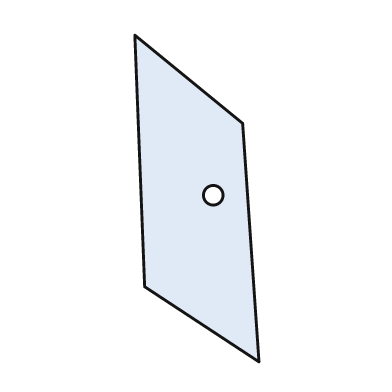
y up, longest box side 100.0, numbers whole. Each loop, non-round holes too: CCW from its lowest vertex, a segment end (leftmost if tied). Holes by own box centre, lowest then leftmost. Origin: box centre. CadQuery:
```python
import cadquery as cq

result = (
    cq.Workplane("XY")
    .moveTo(19.0, -50.0)
    .lineTo(14.0, 23.0)
    .lineTo(-19.0, 50.0)
    .lineTo(-16.0, -27.0)
    .close()
    .moveTo(5.0, 1.0)
    .circle(3.0)
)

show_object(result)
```